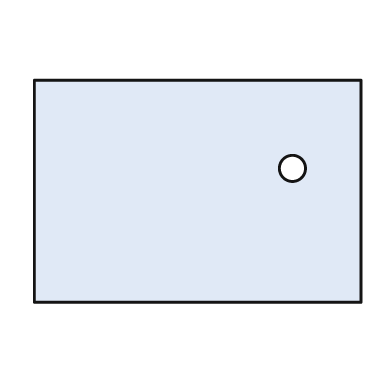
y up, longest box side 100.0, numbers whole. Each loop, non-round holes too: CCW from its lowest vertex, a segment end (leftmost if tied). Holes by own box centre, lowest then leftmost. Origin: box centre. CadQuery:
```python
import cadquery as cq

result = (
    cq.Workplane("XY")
    .moveTo(-50.0, -34.0)
    .lineTo(50.0, -34.0)
    .lineTo(50.0, 34.0)
    .lineTo(-50.0, 34.0)
    .close()
    .moveTo(29.0, 7.0)
    .circle(4.0)
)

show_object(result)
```